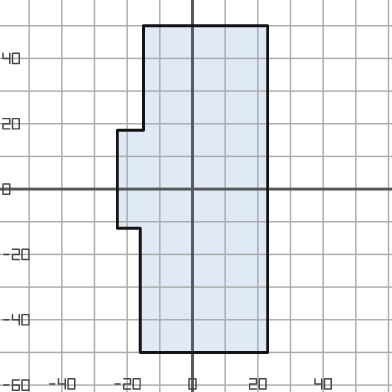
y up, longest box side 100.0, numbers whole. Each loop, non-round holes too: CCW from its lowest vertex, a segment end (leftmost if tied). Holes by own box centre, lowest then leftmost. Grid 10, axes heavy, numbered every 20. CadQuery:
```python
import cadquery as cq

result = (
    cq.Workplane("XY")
    .moveTo(-16.0, -50.0)
    .lineTo(23.0, -50.0)
    .lineTo(23.0, 50.0)
    .lineTo(-15.0, 50.0)
    .lineTo(-15.0, 18.0)
    .lineTo(-23.0, 18.0)
    .lineTo(-23.0, -12.0)
    .lineTo(-16.0, -12.0)
    .close()
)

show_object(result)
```